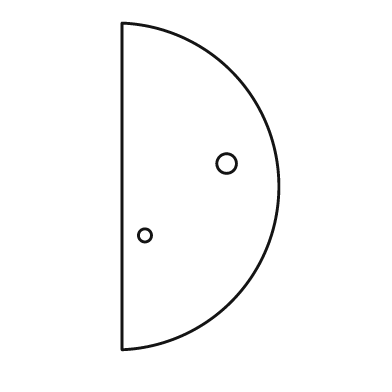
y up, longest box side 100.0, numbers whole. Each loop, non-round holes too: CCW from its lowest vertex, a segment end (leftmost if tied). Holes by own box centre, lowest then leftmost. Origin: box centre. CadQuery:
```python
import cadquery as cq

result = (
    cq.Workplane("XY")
    .moveTo(-24.0, -50.0)
    .threePointArc((24.0, 0.0), (-24.0, 50.0))
    .close()
    .moveTo(-17.0, -15.0)
    .circle(2.0)
    .moveTo(8.0, 7.0)
    .circle(3.0)
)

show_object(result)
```